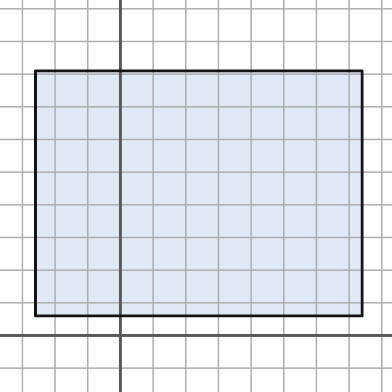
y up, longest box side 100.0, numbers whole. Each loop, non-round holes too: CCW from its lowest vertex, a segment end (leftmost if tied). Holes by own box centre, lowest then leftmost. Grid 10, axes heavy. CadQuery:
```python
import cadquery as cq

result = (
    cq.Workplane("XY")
    .moveTo(-26.0, 6.0)
    .lineTo(74.0, 6.0)
    .lineTo(74.0, 81.0)
    .lineTo(-26.0, 81.0)
    .close()
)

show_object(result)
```